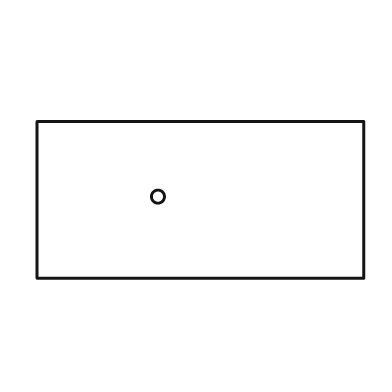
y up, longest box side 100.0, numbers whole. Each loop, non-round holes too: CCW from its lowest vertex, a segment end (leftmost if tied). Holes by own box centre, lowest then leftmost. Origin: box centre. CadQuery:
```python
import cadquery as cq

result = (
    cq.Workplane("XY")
    .moveTo(-50.0, -24.0)
    .lineTo(50.0, -24.0)
    .lineTo(50.0, 24.0)
    .lineTo(-50.0, 24.0)
    .close()
    .moveTo(-13.0, 1.0)
    .circle(2.0)
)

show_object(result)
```